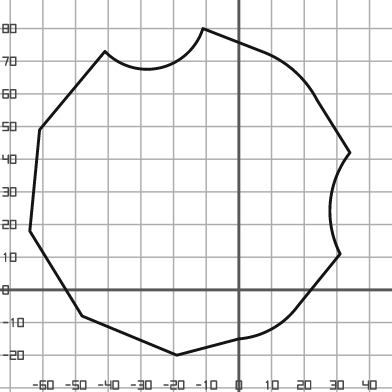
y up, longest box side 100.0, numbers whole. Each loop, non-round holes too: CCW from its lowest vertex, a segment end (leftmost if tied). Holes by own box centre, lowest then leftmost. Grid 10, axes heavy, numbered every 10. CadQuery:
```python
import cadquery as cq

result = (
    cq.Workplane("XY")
    .moveTo(-19.0, -20.0)
    .lineTo(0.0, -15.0)
    .threePointArc((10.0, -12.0), (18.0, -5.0))
    .lineTo(31.0, 11.0)
    .threePointArc((28.0, 27.0), (34.0, 42.0))
    .lineTo(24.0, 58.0)
    .threePointArc((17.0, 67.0), (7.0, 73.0))
    .lineTo(-11.0, 80.0)
    .threePointArc((-24.0, 68.0), (-41.0, 73.0))
    .lineTo(-61.0, 49.0)
    .lineTo(-64.0, 18.0)
    .lineTo(-48.0, -8.0)
    .close()
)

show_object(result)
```